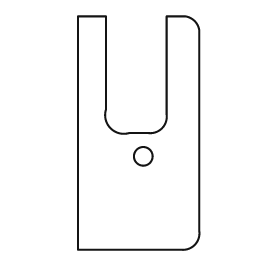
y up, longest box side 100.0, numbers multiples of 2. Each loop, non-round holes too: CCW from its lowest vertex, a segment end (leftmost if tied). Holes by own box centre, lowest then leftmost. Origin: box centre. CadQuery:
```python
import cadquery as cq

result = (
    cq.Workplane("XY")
    .moveTo(-26.0, -50.0)
    .lineTo(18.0, -50.0)
    .threePointArc((24.0, -48.0), (26.0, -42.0))
    .lineTo(26.0, 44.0)
    .threePointArc((24.0, 48.0), (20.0, 50.0))
    .lineTo(12.0, 50.0)
    .lineTo(12.0, 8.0)
    .threePointArc((10.0, 2.0), (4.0, 0.0))
    .lineTo(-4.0, 0.0)
    .threePointArc((-12.0, 2.0), (-14.0, 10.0))
    .lineTo(-14.0, 50.0)
    .lineTo(-26.0, 50.0)
    .close()
    .moveTo(2.0, -10.0)
    .circle(4.0)
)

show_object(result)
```